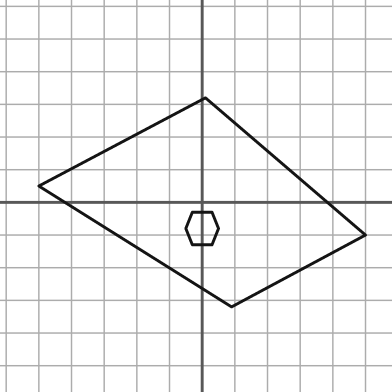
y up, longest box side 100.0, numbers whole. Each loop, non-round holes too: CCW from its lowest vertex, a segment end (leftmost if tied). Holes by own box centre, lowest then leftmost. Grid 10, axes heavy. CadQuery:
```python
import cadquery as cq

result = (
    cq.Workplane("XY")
    .moveTo(9.0, -32.0)
    .lineTo(50.0, -10.0)
    .lineTo(1.0, 32.0)
    .lineTo(-50.0, 5.0)
    .close()
    .moveTo(-3.0, -13.0)
    .lineTo(3.0, -13.0)
    .lineTo(5.0, -8.0)
    .lineTo(3.0, -3.0)
    .lineTo(-3.0, -3.0)
    .lineTo(-5.0, -8.0)
    .close()
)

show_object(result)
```